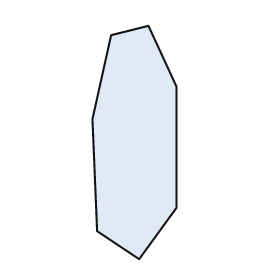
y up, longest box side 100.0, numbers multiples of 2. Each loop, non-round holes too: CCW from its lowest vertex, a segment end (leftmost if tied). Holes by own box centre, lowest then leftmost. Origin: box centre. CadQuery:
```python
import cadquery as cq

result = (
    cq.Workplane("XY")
    .moveTo(2.0, -50.0)
    .lineTo(18.0, -28.0)
    .lineTo(18.0, 24.0)
    .lineTo(6.0, 50.0)
    .lineTo(-10.0, 46.0)
    .lineTo(-18.0, 10.0)
    .lineTo(-16.0, -38.0)
    .close()
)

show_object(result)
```